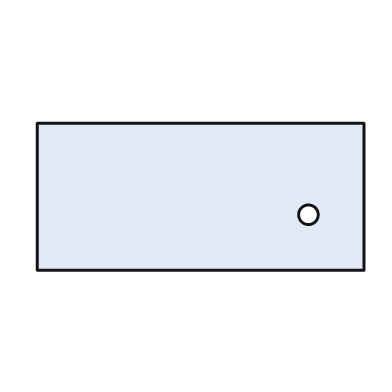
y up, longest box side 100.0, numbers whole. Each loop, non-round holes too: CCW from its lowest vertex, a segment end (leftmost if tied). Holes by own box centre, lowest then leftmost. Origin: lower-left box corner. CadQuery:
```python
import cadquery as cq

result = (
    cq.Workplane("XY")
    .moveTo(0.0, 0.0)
    .lineTo(100.0, 0.0)
    .lineTo(100.0, 45.0)
    .lineTo(0.0, 45.0)
    .close()
    .moveTo(83.0, 17.0)
    .circle(3.0)
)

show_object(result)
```